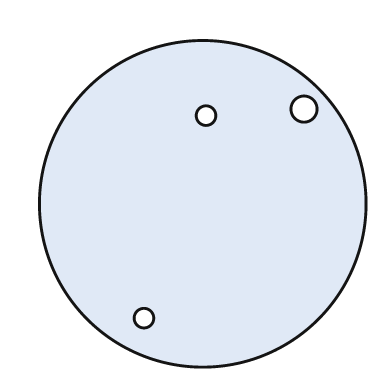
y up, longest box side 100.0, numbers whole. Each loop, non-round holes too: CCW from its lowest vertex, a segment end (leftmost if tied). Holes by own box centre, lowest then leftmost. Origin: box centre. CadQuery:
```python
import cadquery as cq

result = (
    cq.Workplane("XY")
    .moveTo(0.0, 0.0)
    .circle(50.0)
    .moveTo(-18.0, -35.0)
    .circle(3.0)
    .moveTo(1.0, 27.0)
    .circle(3.0)
    .moveTo(31.0, 29.0)
    .circle(4.0)
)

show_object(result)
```